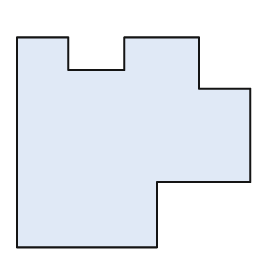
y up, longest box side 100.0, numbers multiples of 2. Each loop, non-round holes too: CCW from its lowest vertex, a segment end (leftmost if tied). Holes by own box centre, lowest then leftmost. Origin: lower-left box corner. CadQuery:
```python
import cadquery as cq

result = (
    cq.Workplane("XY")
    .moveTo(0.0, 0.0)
    .lineTo(60.0, 0.0)
    .lineTo(60.0, 28.0)
    .lineTo(100.0, 28.0)
    .lineTo(100.0, 68.0)
    .lineTo(78.0, 68.0)
    .lineTo(78.0, 90.0)
    .lineTo(46.0, 90.0)
    .lineTo(46.0, 76.0)
    .lineTo(22.0, 76.0)
    .lineTo(22.0, 90.0)
    .lineTo(0.0, 90.0)
    .close()
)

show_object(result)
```